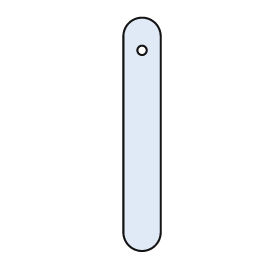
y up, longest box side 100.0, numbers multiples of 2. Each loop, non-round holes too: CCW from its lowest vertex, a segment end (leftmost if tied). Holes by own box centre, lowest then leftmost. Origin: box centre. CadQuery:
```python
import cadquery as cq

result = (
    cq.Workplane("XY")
    .moveTo(-8.0, -42.0)
    .threePointArc((0.0, -50.0), (8.0, -42.0))
    .lineTo(8.0, 42.0)
    .threePointArc((0.0, 50.0), (-8.0, 42.0))
    .close()
    .moveTo(0.0, 36.0)
    .circle(2.0)
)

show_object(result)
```